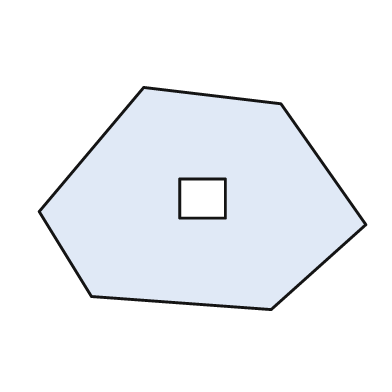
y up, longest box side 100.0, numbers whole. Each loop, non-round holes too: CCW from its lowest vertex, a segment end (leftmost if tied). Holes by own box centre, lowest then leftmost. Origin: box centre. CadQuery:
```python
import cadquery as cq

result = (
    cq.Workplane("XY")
    .moveTo(21.0, -34.0)
    .lineTo(50.0, -8.0)
    .lineTo(24.0, 29.0)
    .lineTo(-18.0, 34.0)
    .lineTo(-50.0, -4.0)
    .lineTo(-34.0, -30.0)
    .close()
    .moveTo(-7.0, -6.0)
    .lineTo(7.0, -6.0)
    .lineTo(7.0, 6.0)
    .lineTo(-7.0, 6.0)
    .close()
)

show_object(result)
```